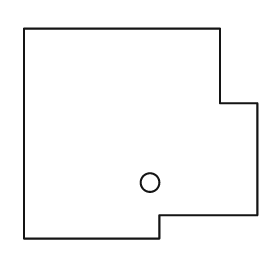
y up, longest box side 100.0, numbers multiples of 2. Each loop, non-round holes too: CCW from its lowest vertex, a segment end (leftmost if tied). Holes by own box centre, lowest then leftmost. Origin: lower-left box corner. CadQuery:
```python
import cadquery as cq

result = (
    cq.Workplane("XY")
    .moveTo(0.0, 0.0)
    .lineTo(58.0, 0.0)
    .lineTo(58.0, 10.0)
    .lineTo(100.0, 10.0)
    .lineTo(100.0, 58.0)
    .lineTo(84.0, 58.0)
    .lineTo(84.0, 90.0)
    .lineTo(0.0, 90.0)
    .close()
    .moveTo(54.0, 24.0)
    .circle(4.0)
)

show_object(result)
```